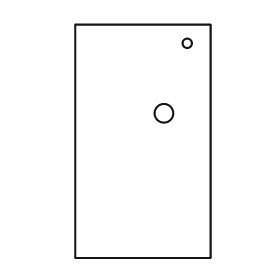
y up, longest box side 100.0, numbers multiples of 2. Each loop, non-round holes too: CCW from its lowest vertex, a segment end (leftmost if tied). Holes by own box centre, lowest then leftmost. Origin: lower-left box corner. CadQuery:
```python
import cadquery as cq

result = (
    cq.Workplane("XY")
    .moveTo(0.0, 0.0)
    .lineTo(58.0, 0.0)
    .lineTo(58.0, 100.0)
    .lineTo(0.0, 100.0)
    .close()
    .moveTo(38.0, 62.0)
    .circle(4.0)
    .moveTo(48.0, 92.0)
    .circle(2.0)
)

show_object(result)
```